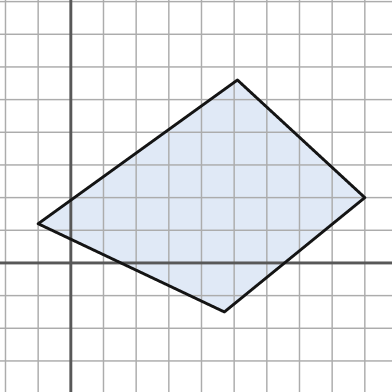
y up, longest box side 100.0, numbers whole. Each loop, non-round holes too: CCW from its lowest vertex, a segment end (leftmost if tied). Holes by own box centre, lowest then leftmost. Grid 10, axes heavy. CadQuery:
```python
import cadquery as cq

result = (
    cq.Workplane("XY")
    .moveTo(47.0, -15.0)
    .lineTo(90.0, 20.0)
    .lineTo(51.0, 56.0)
    .lineTo(-10.0, 12.0)
    .close()
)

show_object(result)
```